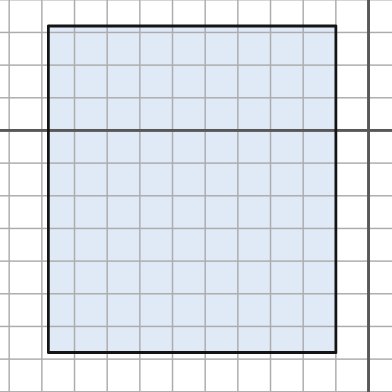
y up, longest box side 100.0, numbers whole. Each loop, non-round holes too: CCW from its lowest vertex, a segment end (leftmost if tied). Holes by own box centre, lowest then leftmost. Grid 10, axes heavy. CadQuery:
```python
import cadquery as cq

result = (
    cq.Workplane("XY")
    .moveTo(-98.0, -68.0)
    .lineTo(-10.0, -68.0)
    .lineTo(-10.0, 32.0)
    .lineTo(-98.0, 32.0)
    .close()
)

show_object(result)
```